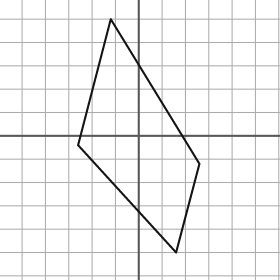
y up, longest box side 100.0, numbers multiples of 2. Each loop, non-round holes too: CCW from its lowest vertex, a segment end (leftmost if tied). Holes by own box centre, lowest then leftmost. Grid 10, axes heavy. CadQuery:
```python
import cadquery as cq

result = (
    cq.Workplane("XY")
    .moveTo(16.0, -50.0)
    .lineTo(26.0, -12.0)
    .lineTo(-12.0, 50.0)
    .lineTo(-26.0, -4.0)
    .close()
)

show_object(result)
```